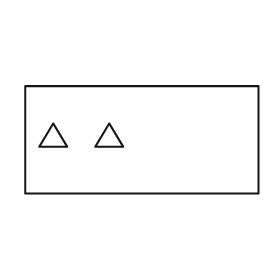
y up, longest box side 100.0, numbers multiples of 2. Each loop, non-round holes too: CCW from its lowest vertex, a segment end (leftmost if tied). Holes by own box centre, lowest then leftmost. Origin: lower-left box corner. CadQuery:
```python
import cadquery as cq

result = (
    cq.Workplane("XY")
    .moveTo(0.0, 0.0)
    .lineTo(100.0, 0.0)
    .lineTo(100.0, 46.0)
    .lineTo(0.0, 46.0)
    .close()
    .moveTo(6.0, 20.0)
    .lineTo(18.0, 20.0)
    .lineTo(12.0, 30.0)
    .close()
    .moveTo(30.0, 20.0)
    .lineTo(42.0, 20.0)
    .lineTo(36.0, 30.0)
    .close()
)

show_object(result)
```